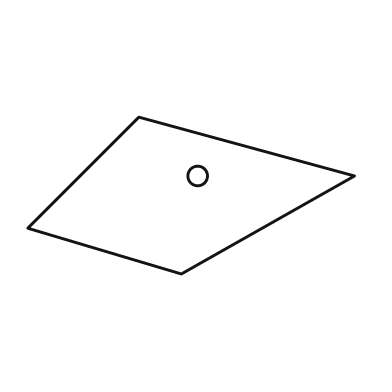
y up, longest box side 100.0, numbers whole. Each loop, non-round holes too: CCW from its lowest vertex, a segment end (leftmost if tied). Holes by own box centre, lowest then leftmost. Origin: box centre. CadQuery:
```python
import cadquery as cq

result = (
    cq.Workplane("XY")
    .moveTo(-3.0, -24.0)
    .lineTo(50.0, 6.0)
    .lineTo(-16.0, 24.0)
    .lineTo(-50.0, -10.0)
    .close()
    .moveTo(2.0, 6.0)
    .circle(3.0)
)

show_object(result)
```